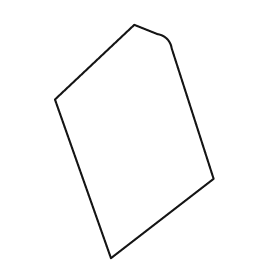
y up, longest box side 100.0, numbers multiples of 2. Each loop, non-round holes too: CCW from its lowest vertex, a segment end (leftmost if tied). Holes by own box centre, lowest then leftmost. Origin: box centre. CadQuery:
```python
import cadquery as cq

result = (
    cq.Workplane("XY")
    .moveTo(-10.0, -50.0)
    .lineTo(34.0, -16.0)
    .lineTo(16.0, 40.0)
    .threePointArc((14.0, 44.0), (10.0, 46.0))
    .lineTo(0.0, 50.0)
    .lineTo(-34.0, 18.0)
    .close()
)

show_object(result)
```